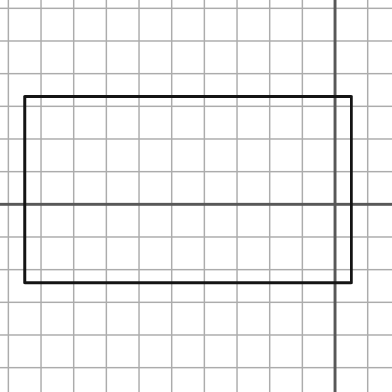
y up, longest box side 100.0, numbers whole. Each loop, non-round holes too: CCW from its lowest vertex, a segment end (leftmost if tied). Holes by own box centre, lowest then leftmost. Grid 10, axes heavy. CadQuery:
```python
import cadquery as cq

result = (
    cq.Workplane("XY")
    .moveTo(-95.0, -24.0)
    .lineTo(5.0, -24.0)
    .lineTo(5.0, 33.0)
    .lineTo(-95.0, 33.0)
    .close()
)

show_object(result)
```